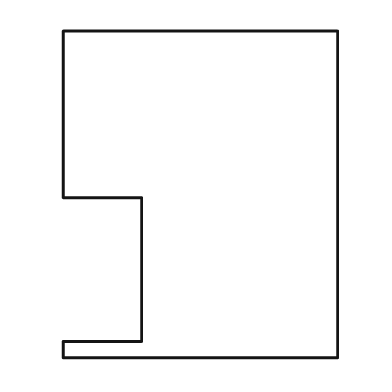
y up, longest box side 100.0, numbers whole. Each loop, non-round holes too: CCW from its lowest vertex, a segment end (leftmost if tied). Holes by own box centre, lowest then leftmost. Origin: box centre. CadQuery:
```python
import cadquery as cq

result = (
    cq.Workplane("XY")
    .moveTo(-42.0, -50.0)
    .lineTo(42.0, -50.0)
    .lineTo(42.0, 50.0)
    .lineTo(-42.0, 50.0)
    .lineTo(-42.0, -1.0)
    .lineTo(-18.0, -1.0)
    .lineTo(-18.0, -45.0)
    .lineTo(-42.0, -45.0)
    .close()
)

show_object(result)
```